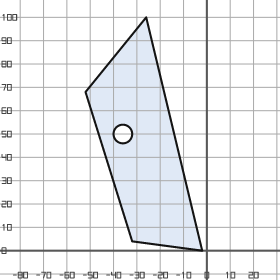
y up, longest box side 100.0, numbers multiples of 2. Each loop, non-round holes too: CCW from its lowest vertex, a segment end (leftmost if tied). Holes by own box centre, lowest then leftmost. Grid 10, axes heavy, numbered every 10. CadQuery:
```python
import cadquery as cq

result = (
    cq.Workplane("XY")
    .moveTo(-2.0, 0.0)
    .lineTo(-26.0, 100.0)
    .lineTo(-52.0, 68.0)
    .lineTo(-32.0, 4.0)
    .close()
    .moveTo(-36.0, 50.0)
    .circle(4.0)
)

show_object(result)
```